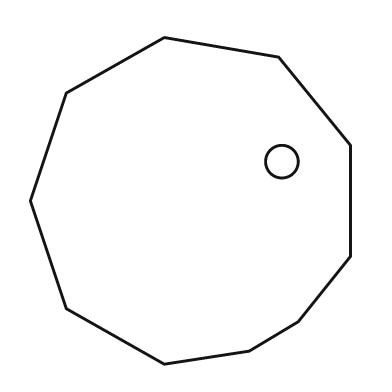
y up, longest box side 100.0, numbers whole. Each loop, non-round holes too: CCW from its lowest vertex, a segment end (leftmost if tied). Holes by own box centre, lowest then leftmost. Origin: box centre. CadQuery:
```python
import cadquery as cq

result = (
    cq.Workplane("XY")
    .moveTo(-8.0, -50.0)
    .lineTo(18.0, -46.0)
    .lineTo(33.0, -37.0)
    .lineTo(49.0, -17.0)
    .lineTo(49.0, 17.0)
    .lineTo(27.0, 44.0)
    .lineTo(-8.0, 50.0)
    .lineTo(-38.0, 33.0)
    .lineTo(-49.0, 0.0)
    .lineTo(-38.0, -33.0)
    .close()
    .moveTo(28.0, 12.0)
    .circle(5.0)
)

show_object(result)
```